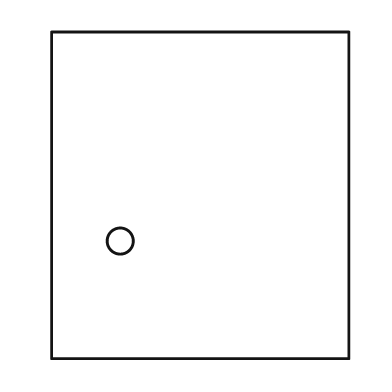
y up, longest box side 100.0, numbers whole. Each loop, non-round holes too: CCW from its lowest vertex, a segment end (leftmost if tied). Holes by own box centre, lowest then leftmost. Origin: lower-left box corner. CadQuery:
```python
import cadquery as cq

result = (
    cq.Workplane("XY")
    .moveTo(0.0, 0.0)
    .lineTo(91.0, 0.0)
    .lineTo(91.0, 100.0)
    .lineTo(0.0, 100.0)
    .close()
    .moveTo(21.0, 36.0)
    .circle(4.0)
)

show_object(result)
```